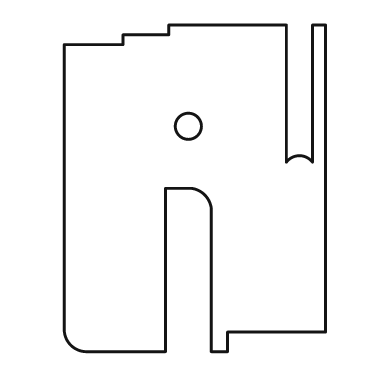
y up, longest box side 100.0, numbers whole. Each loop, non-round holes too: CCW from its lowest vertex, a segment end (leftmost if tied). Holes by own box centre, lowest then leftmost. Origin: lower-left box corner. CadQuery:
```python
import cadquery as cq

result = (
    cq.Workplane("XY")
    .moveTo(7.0, 0.0)
    .lineTo(31.0, 0.0)
    .lineTo(31.0, 50.0)
    .lineTo(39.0, 50.0)
    .threePointArc((43.0, 48.0), (45.0, 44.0))
    .lineTo(45.0, 0.0)
    .lineTo(50.0, 0.0)
    .lineTo(50.0, 6.0)
    .lineTo(80.0, 6.0)
    .lineTo(80.0, 100.0)
    .lineTo(76.0, 100.0)
    .lineTo(76.0, 58.0)
    .threePointArc((72.0, 60.0), (68.0, 58.0))
    .lineTo(68.0, 100.0)
    .lineTo(32.0, 100.0)
    .lineTo(32.0, 97.0)
    .lineTo(18.0, 97.0)
    .lineTo(18.0, 94.0)
    .lineTo(0.0, 94.0)
    .lineTo(0.0, 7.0)
    .threePointArc((2.0, 2.0), (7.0, 0.0))
    .close()
    .moveTo(38.0, 69.0)
    .circle(4.0)
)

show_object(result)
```